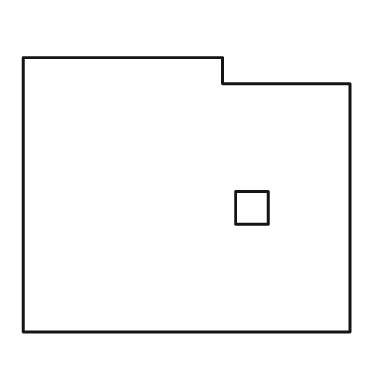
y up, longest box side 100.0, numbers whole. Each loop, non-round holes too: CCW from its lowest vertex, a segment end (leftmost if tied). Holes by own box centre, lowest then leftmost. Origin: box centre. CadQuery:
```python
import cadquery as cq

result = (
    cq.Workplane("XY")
    .moveTo(-50.0, -42.0)
    .lineTo(50.0, -42.0)
    .lineTo(50.0, 34.0)
    .lineTo(11.0, 34.0)
    .lineTo(11.0, 42.0)
    .lineTo(-50.0, 42.0)
    .close()
    .moveTo(15.0, -9.0)
    .lineTo(25.0, -9.0)
    .lineTo(25.0, 1.0)
    .lineTo(15.0, 1.0)
    .close()
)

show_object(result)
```